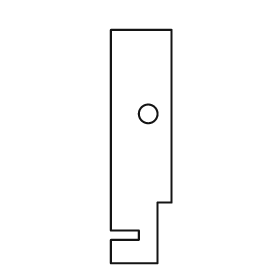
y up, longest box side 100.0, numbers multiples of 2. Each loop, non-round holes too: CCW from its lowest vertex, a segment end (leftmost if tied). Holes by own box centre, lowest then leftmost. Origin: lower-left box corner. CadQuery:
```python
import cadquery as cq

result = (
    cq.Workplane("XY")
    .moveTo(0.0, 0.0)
    .lineTo(20.0, 0.0)
    .lineTo(20.0, 26.0)
    .lineTo(26.0, 26.0)
    .lineTo(26.0, 100.0)
    .lineTo(0.0, 100.0)
    .lineTo(0.0, 14.0)
    .lineTo(12.0, 14.0)
    .lineTo(12.0, 10.0)
    .lineTo(0.0, 10.0)
    .close()
    .moveTo(16.0, 64.0)
    .circle(4.0)
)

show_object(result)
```